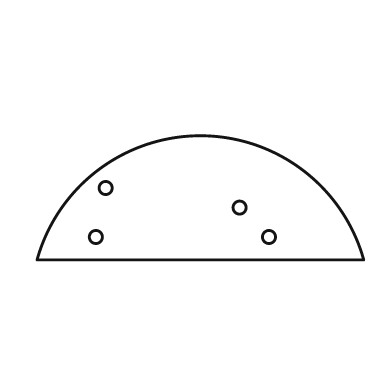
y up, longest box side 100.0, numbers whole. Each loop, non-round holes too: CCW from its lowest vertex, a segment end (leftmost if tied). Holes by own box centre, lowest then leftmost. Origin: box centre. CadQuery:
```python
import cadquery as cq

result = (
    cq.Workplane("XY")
    .moveTo(-50.0, -19.0)
    .lineTo(50.0, -19.0)
    .threePointArc((0.0, 19.0), (-50.0, -19.0))
    .close()
    .moveTo(-32.0, -12.0)
    .circle(2.0)
    .moveTo(21.0, -12.0)
    .circle(2.0)
    .moveTo(12.0, -3.0)
    .circle(2.0)
    .moveTo(-29.0, 3.0)
    .circle(2.0)
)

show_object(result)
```